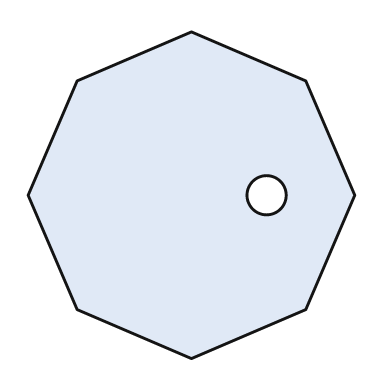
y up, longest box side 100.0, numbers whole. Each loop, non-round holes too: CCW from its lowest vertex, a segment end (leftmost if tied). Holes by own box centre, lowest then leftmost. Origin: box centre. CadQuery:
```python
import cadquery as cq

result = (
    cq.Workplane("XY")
    .moveTo(0.0, -50.0)
    .lineTo(35.0, -35.0)
    .lineTo(50.0, 0.0)
    .lineTo(35.0, 35.0)
    .lineTo(0.0, 50.0)
    .lineTo(-35.0, 35.0)
    .lineTo(-50.0, 0.0)
    .lineTo(-35.0, -35.0)
    .close()
    .moveTo(23.0, 0.0)
    .circle(6.0)
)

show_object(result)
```